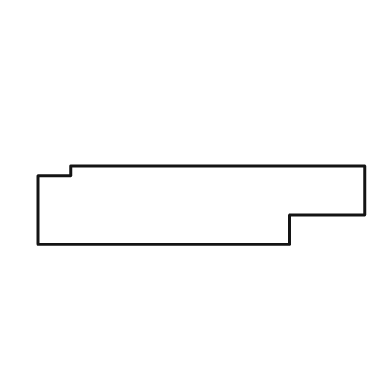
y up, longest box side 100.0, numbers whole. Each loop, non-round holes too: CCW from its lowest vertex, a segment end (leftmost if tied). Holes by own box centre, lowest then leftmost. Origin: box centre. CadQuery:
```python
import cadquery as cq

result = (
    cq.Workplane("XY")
    .moveTo(-50.0, -12.0)
    .lineTo(27.0, -12.0)
    .lineTo(27.0, -3.0)
    .lineTo(50.0, -3.0)
    .lineTo(50.0, 12.0)
    .lineTo(-40.0, 12.0)
    .lineTo(-40.0, 9.0)
    .lineTo(-50.0, 9.0)
    .close()
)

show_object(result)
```